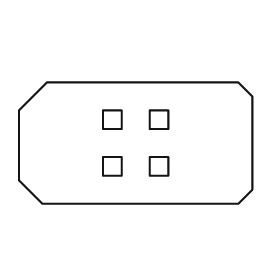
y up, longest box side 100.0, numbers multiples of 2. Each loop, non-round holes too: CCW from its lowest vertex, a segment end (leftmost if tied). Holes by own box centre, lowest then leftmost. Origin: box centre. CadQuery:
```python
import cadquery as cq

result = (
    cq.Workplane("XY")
    .moveTo(-40.0, -26.0)
    .lineTo(44.0, -26.0)
    .lineTo(50.0, -20.0)
    .lineTo(50.0, 20.0)
    .lineTo(44.0, 26.0)
    .lineTo(-38.0, 26.0)
    .lineTo(-50.0, 14.0)
    .lineTo(-50.0, -16.0)
    .close()
    .moveTo(-14.0, -14.0)
    .lineTo(-6.0, -14.0)
    .lineTo(-6.0, -6.0)
    .lineTo(-14.0, -6.0)
    .close()
    .moveTo(6.0, -14.0)
    .lineTo(14.0, -14.0)
    .lineTo(14.0, -6.0)
    .lineTo(6.0, -6.0)
    .close()
    .moveTo(-14.0, 6.0)
    .lineTo(-6.0, 6.0)
    .lineTo(-6.0, 14.0)
    .lineTo(-14.0, 14.0)
    .close()
    .moveTo(6.0, 6.0)
    .lineTo(14.0, 6.0)
    .lineTo(14.0, 14.0)
    .lineTo(6.0, 14.0)
    .close()
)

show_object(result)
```